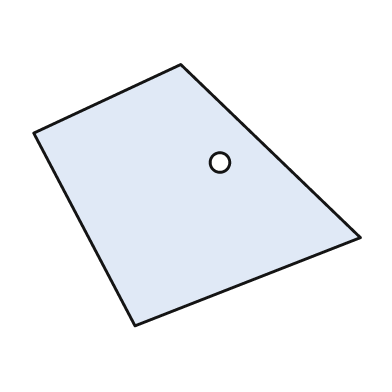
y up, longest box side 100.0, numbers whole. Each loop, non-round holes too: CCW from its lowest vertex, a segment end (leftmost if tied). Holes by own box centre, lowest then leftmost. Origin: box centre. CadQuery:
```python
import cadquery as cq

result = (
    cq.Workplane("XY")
    .moveTo(-19.0, -40.0)
    .lineTo(50.0, -13.0)
    .lineTo(-5.0, 40.0)
    .lineTo(-50.0, 19.0)
    .close()
    .moveTo(7.0, 10.0)
    .circle(3.0)
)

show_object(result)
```